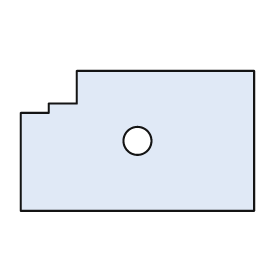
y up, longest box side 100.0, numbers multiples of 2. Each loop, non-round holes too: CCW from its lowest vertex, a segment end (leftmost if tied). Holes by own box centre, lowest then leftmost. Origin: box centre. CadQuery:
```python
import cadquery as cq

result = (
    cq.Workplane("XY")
    .moveTo(-50.0, -30.0)
    .lineTo(50.0, -30.0)
    .lineTo(50.0, 30.0)
    .lineTo(-26.0, 30.0)
    .lineTo(-26.0, 16.0)
    .lineTo(-38.0, 16.0)
    .lineTo(-38.0, 12.0)
    .lineTo(-50.0, 12.0)
    .close()
    .moveTo(0.0, 0.0)
    .circle(6.0)
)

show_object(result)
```